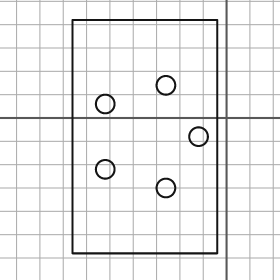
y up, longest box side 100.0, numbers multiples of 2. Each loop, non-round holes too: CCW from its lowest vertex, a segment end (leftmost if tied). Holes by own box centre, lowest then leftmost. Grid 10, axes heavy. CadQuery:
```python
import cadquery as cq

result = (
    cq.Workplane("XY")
    .moveTo(-66.0, -58.0)
    .lineTo(-4.0, -58.0)
    .lineTo(-4.0, 42.0)
    .lineTo(-66.0, 42.0)
    .close()
    .moveTo(-26.0, -30.0)
    .circle(4.0)
    .moveTo(-52.0, -22.0)
    .circle(4.0)
    .moveTo(-12.0, -8.0)
    .circle(4.0)
    .moveTo(-52.0, 6.0)
    .circle(4.0)
    .moveTo(-26.0, 14.0)
    .circle(4.0)
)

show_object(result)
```